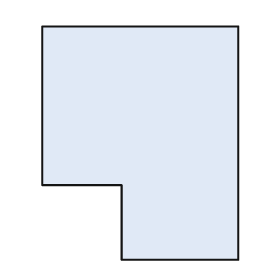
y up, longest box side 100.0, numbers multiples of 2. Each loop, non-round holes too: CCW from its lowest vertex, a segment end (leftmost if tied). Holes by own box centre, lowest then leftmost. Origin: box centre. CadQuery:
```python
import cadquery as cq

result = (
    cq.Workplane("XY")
    .moveTo(-8.0, -50.0)
    .lineTo(42.0, -50.0)
    .lineTo(42.0, 50.0)
    .lineTo(-42.0, 50.0)
    .lineTo(-42.0, -18.0)
    .lineTo(-8.0, -18.0)
    .close()
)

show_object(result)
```